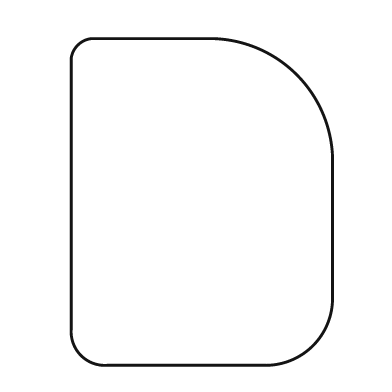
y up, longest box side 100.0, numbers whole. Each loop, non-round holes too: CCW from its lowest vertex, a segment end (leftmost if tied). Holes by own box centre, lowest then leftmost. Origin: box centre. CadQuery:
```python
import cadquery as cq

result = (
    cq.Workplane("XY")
    .moveTo(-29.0, -50.0)
    .lineTo(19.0, -50.0)
    .threePointArc((34.0, -44.0), (40.0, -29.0))
    .lineTo(40.0, 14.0)
    .threePointArc((29.0, 39.0), (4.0, 50.0))
    .lineTo(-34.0, 50.0)
    .threePointArc((-38.0, 48.0), (-40.0, 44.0))
    .lineTo(-40.0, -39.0)
    .threePointArc((-37.0, -47.0), (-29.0, -50.0))
    .close()
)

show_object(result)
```